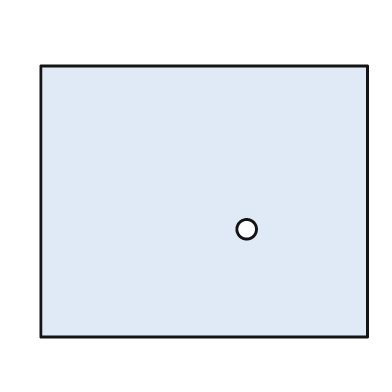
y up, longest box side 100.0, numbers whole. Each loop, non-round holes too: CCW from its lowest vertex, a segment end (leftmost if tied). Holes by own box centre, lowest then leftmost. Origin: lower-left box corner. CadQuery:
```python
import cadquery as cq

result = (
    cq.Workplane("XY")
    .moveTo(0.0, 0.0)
    .lineTo(100.0, 0.0)
    .lineTo(100.0, 83.0)
    .lineTo(0.0, 83.0)
    .close()
    .moveTo(63.0, 33.0)
    .circle(3.0)
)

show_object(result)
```